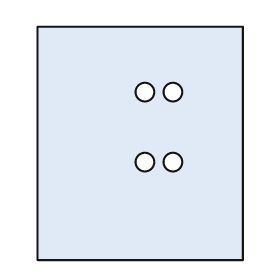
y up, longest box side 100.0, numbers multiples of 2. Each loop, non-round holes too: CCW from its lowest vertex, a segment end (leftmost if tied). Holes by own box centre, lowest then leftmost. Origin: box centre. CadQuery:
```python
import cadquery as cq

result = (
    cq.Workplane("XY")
    .moveTo(-44.0, -50.0)
    .lineTo(44.0, -50.0)
    .lineTo(44.0, 50.0)
    .lineTo(-44.0, 50.0)
    .close()
    .moveTo(2.0, -8.0)
    .circle(4.0)
    .moveTo(14.0, -8.0)
    .circle(4.0)
    .moveTo(2.0, 22.0)
    .circle(4.0)
    .moveTo(14.0, 22.0)
    .circle(4.0)
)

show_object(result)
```